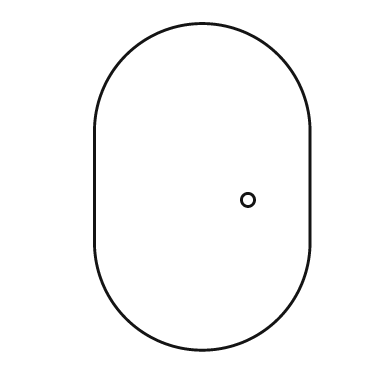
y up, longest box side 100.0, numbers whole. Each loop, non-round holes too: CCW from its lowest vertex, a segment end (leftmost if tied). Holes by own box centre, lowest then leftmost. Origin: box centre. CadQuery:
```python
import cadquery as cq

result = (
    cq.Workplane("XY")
    .moveTo(-33.0, -17.0)
    .threePointArc((0.0, -50.0), (33.0, -17.0))
    .lineTo(33.0, 17.0)
    .threePointArc((0.0, 50.0), (-33.0, 17.0))
    .close()
    .moveTo(14.0, -4.0)
    .circle(2.0)
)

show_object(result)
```